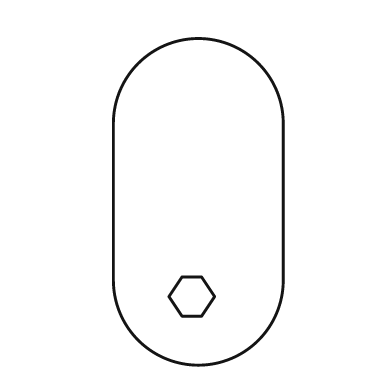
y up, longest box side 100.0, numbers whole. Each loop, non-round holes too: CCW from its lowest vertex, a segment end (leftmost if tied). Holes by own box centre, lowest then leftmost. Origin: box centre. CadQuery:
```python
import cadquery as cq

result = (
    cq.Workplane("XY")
    .moveTo(-26.0, -24.0)
    .threePointArc((0.0, -50.0), (26.0, -24.0))
    .lineTo(26.0, 24.0)
    .threePointArc((0.0, 50.0), (-26.0, 24.0))
    .close()
    .moveTo(-5.0, -35.0)
    .lineTo(1.0, -35.0)
    .lineTo(5.0, -29.0)
    .lineTo(1.0, -23.0)
    .lineTo(-5.0, -23.0)
    .lineTo(-9.0, -29.0)
    .close()
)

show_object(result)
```